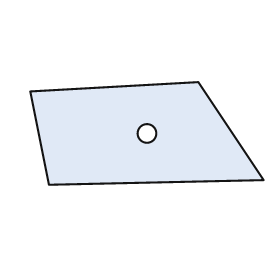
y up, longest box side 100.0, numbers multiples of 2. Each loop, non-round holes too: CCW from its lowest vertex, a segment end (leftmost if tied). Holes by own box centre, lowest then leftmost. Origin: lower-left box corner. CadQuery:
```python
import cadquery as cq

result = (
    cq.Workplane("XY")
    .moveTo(8.0, 0.0)
    .lineTo(100.0, 2.0)
    .lineTo(72.0, 44.0)
    .lineTo(0.0, 40.0)
    .close()
    .moveTo(50.0, 22.0)
    .circle(4.0)
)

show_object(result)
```